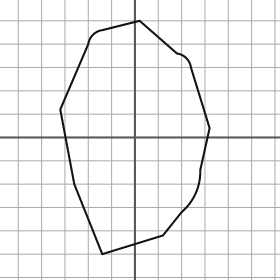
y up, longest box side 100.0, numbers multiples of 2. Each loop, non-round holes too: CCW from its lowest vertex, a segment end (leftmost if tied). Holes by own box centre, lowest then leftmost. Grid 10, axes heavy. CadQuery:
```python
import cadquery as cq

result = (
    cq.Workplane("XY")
    .moveTo(-14.0, -50.0)
    .lineTo(12.0, -42.0)
    .lineTo(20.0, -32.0)
    .threePointArc((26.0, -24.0), (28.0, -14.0))
    .lineTo(32.0, 4.0)
    .lineTo(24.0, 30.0)
    .threePointArc((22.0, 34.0), (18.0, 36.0))
    .lineTo(2.0, 50.0)
    .lineTo(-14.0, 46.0)
    .threePointArc((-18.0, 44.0), (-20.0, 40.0))
    .lineTo(-32.0, 12.0)
    .lineTo(-26.0, -20.0)
    .close()
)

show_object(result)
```